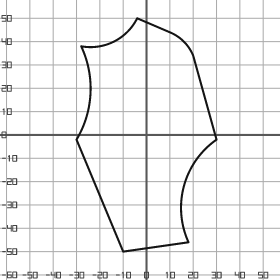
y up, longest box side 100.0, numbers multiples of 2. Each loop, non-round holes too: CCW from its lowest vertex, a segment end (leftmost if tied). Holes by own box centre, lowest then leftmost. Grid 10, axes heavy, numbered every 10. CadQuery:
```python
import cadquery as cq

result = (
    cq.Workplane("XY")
    .moveTo(-10.0, -50.0)
    .lineTo(18.0, -46.0)
    .threePointArc((16.0, -22.0), (30.0, -2.0))
    .lineTo(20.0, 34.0)
    .threePointArc((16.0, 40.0), (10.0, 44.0))
    .lineTo(-4.0, 50.0)
    .threePointArc((-14.0, 40.0), (-28.0, 38.0))
    .threePointArc((-24.0, 18.0), (-30.0, -2.0))
    .close()
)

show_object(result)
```